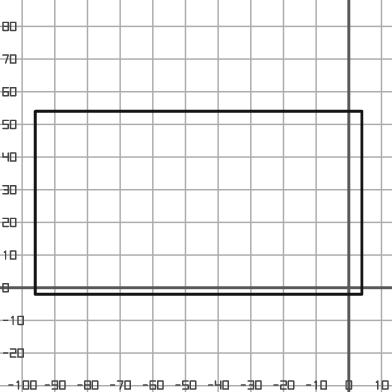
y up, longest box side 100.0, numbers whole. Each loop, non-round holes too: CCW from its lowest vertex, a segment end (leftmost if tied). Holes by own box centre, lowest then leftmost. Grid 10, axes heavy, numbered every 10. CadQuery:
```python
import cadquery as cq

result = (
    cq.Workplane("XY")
    .moveTo(-96.0, -2.0)
    .lineTo(4.0, -2.0)
    .lineTo(4.0, 54.0)
    .lineTo(-96.0, 54.0)
    .close()
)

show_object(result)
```